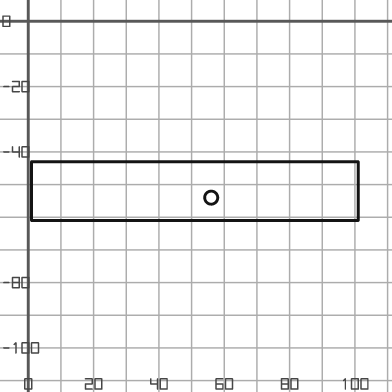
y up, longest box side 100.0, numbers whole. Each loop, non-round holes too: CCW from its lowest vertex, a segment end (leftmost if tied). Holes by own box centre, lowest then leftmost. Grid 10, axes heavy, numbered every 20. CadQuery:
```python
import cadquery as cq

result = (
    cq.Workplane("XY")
    .moveTo(1.0, -61.0)
    .lineTo(101.0, -61.0)
    .lineTo(101.0, -43.0)
    .lineTo(1.0, -43.0)
    .close()
    .moveTo(56.0, -54.0)
    .circle(2.0)
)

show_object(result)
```